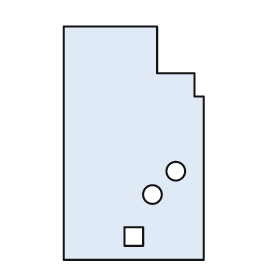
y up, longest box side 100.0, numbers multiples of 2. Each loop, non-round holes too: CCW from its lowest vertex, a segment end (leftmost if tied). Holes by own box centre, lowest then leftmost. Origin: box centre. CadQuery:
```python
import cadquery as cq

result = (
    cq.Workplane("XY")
    .moveTo(-30.0, -50.0)
    .lineTo(30.0, -50.0)
    .lineTo(30.0, 20.0)
    .lineTo(26.0, 20.0)
    .lineTo(26.0, 30.0)
    .lineTo(10.0, 30.0)
    .lineTo(10.0, 50.0)
    .lineTo(-30.0, 50.0)
    .close()
    .moveTo(-4.0, -44.0)
    .lineTo(4.0, -44.0)
    .lineTo(4.0, -36.0)
    .lineTo(-4.0, -36.0)
    .close()
    .moveTo(8.0, -22.0)
    .circle(4.0)
    .moveTo(18.0, -12.0)
    .circle(4.0)
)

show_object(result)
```